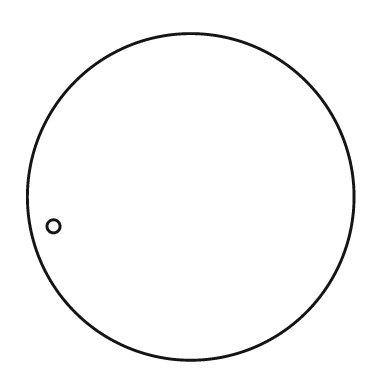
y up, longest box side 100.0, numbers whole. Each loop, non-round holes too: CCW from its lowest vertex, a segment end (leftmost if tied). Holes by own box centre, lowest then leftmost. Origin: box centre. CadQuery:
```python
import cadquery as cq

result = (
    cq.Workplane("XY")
    .moveTo(0.0, 0.0)
    .circle(50.0)
    .moveTo(-42.0, -9.0)
    .circle(2.0)
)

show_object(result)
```